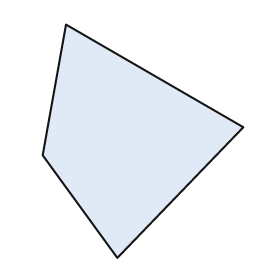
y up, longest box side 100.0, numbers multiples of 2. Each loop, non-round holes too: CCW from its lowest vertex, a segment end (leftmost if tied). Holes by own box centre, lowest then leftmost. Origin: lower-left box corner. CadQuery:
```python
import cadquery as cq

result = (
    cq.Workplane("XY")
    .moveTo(32.0, 0.0)
    .lineTo(86.0, 56.0)
    .lineTo(10.0, 100.0)
    .lineTo(0.0, 44.0)
    .close()
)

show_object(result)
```